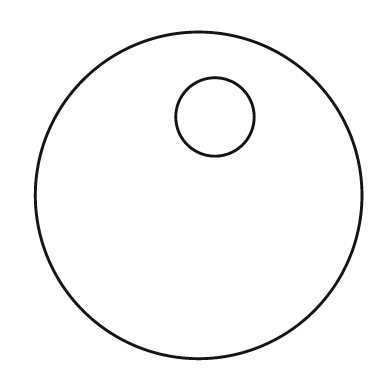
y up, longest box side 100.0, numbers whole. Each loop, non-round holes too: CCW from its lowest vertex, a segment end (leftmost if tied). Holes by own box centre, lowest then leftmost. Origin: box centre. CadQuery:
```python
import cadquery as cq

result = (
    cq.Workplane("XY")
    .moveTo(0.0, 0.0)
    .circle(50.0)
    .moveTo(5.0, 24.0)
    .circle(12.0)
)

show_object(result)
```